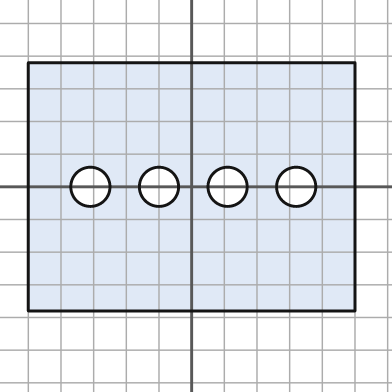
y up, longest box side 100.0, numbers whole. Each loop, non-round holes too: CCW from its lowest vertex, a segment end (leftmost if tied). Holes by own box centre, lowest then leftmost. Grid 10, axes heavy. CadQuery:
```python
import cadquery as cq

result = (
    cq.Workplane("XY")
    .moveTo(-50.0, -38.0)
    .lineTo(50.0, -38.0)
    .lineTo(50.0, 38.0)
    .lineTo(-50.0, 38.0)
    .close()
    .moveTo(-31.0, 0.0)
    .circle(6.0)
    .moveTo(-10.0, 0.0)
    .circle(6.0)
    .moveTo(11.0, 0.0)
    .circle(6.0)
    .moveTo(32.0, 0.0)
    .circle(6.0)
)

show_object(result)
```